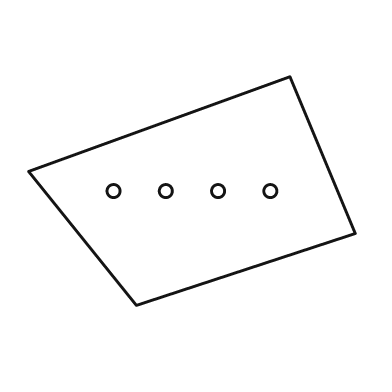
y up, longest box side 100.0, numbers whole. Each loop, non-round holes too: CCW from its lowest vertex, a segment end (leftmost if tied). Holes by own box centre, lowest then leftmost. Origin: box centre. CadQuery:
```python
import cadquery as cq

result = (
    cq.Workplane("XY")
    .moveTo(-17.0, -35.0)
    .lineTo(50.0, -13.0)
    .lineTo(30.0, 35.0)
    .lineTo(-50.0, 6.0)
    .close()
    .moveTo(-24.0, 0.0)
    .circle(2.0)
    .moveTo(-8.0, 0.0)
    .circle(2.0)
    .moveTo(8.0, 0.0)
    .circle(2.0)
    .moveTo(24.0, 0.0)
    .circle(2.0)
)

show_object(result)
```